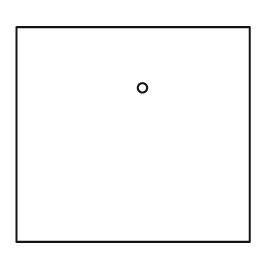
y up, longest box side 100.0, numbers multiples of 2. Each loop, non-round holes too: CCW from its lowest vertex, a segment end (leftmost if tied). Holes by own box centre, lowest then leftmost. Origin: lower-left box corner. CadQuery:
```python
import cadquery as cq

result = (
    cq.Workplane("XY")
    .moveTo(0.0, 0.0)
    .lineTo(100.0, 0.0)
    .lineTo(100.0, 92.0)
    .lineTo(0.0, 92.0)
    .close()
    .moveTo(54.0, 66.0)
    .circle(2.0)
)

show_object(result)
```